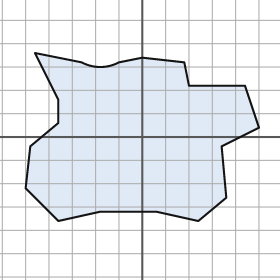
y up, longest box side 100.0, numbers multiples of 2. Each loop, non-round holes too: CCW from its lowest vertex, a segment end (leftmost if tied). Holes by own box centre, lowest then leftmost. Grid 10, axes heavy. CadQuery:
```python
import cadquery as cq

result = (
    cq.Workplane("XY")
    .moveTo(-36.0, -36.0)
    .lineTo(-18.0, -32.0)
    .lineTo(6.0, -32.0)
    .lineTo(24.0, -36.0)
    .lineTo(36.0, -26.0)
    .lineTo(34.0, -4.0)
    .lineTo(50.0, 4.0)
    .lineTo(44.0, 22.0)
    .lineTo(20.0, 22.0)
    .lineTo(18.0, 32.0)
    .lineTo(0.0, 34.0)
    .lineTo(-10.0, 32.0)
    .threePointArc((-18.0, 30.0), (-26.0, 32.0))
    .lineTo(-46.0, 36.0)
    .lineTo(-36.0, 16.0)
    .lineTo(-36.0, 6.0)
    .lineTo(-48.0, -4.0)
    .lineTo(-50.0, -22.0)
    .close()
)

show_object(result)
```